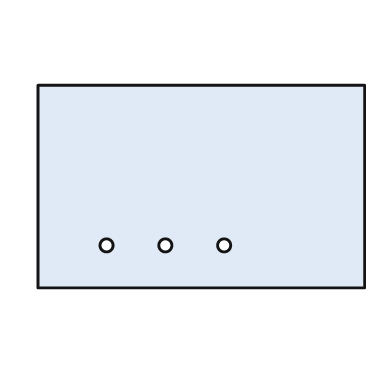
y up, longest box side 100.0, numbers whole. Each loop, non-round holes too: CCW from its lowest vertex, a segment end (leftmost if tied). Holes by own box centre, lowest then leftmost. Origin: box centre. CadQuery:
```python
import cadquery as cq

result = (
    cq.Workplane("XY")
    .moveTo(-50.0, -31.0)
    .lineTo(50.0, -31.0)
    .lineTo(50.0, 31.0)
    .lineTo(-50.0, 31.0)
    .close()
    .moveTo(-29.0, -18.0)
    .circle(2.0)
    .moveTo(-11.0, -18.0)
    .circle(2.0)
    .moveTo(7.0, -18.0)
    .circle(2.0)
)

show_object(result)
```